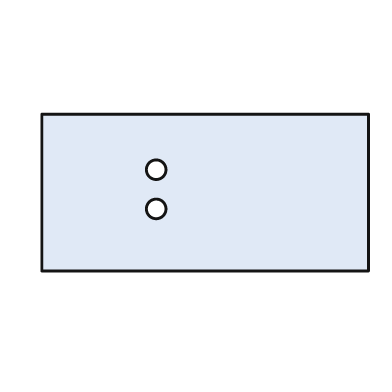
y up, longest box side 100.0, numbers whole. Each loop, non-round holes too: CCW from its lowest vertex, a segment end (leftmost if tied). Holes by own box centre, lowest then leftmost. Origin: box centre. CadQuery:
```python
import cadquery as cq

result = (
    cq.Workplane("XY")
    .moveTo(-50.0, -24.0)
    .lineTo(50.0, -24.0)
    .lineTo(50.0, 24.0)
    .lineTo(-50.0, 24.0)
    .close()
    .moveTo(-15.0, -5.0)
    .circle(3.0)
    .moveTo(-15.0, 7.0)
    .circle(3.0)
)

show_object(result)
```